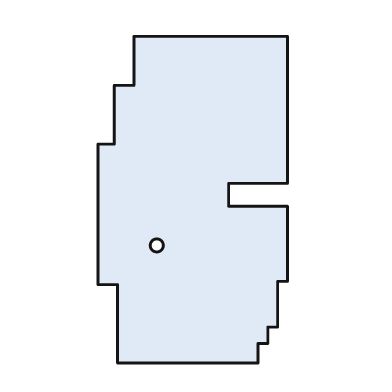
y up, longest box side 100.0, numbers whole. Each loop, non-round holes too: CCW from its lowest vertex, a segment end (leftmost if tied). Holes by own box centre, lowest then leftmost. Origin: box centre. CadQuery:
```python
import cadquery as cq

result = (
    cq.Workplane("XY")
    .moveTo(-23.0, -50.0)
    .lineTo(20.0, -50.0)
    .lineTo(20.0, -44.0)
    .lineTo(23.0, -44.0)
    .lineTo(23.0, -39.0)
    .lineTo(26.0, -39.0)
    .lineTo(26.0, -25.0)
    .lineTo(29.0, -25.0)
    .lineTo(29.0, -2.0)
    .lineTo(11.0, -2.0)
    .lineTo(11.0, 5.0)
    .lineTo(29.0, 5.0)
    .lineTo(29.0, 50.0)
    .lineTo(-18.0, 50.0)
    .lineTo(-18.0, 35.0)
    .lineTo(-24.0, 35.0)
    .lineTo(-24.0, 17.0)
    .lineTo(-29.0, 17.0)
    .lineTo(-29.0, -26.0)
    .lineTo(-23.0, -26.0)
    .close()
    .moveTo(-11.0, -14.0)
    .circle(2.0)
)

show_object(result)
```